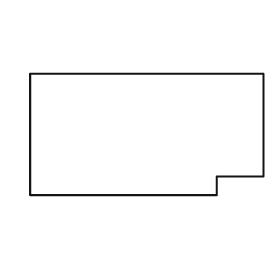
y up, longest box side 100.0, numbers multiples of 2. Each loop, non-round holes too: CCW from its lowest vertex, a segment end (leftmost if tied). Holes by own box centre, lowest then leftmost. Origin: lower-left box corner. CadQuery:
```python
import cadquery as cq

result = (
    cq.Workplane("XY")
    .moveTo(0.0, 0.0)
    .lineTo(80.0, 0.0)
    .lineTo(80.0, 8.0)
    .lineTo(100.0, 8.0)
    .lineTo(100.0, 52.0)
    .lineTo(0.0, 52.0)
    .close()
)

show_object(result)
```